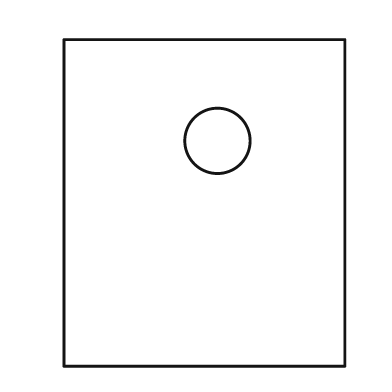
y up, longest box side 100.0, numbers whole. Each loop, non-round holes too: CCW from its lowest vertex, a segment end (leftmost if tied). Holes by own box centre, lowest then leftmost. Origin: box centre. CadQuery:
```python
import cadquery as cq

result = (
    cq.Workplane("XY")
    .moveTo(-43.0, -50.0)
    .lineTo(43.0, -50.0)
    .lineTo(43.0, 50.0)
    .lineTo(-43.0, 50.0)
    .close()
    .moveTo(4.0, 19.0)
    .circle(10.0)
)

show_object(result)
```